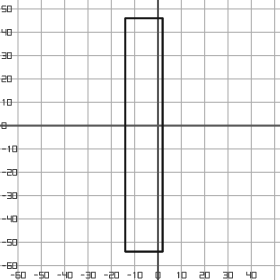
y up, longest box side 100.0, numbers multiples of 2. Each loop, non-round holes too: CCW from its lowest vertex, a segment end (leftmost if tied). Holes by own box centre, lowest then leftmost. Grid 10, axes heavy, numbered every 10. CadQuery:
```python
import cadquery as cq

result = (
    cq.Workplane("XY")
    .moveTo(-14.0, -54.0)
    .lineTo(2.0, -54.0)
    .lineTo(2.0, 46.0)
    .lineTo(-14.0, 46.0)
    .close()
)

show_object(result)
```